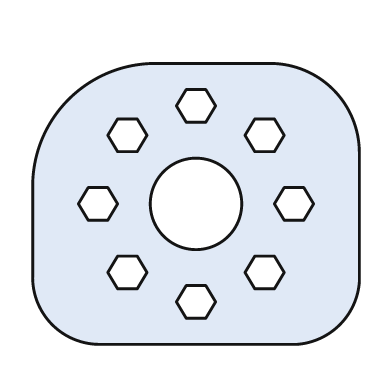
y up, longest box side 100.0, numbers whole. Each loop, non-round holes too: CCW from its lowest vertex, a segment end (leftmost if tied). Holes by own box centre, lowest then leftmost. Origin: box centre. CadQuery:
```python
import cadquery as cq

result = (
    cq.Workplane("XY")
    .moveTo(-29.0, -43.0)
    .lineTo(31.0, -43.0)
    .threePointArc((44.0, -37.0), (50.0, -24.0))
    .lineTo(50.0, 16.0)
    .threePointArc((42.0, 35.0), (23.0, 43.0))
    .lineTo(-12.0, 43.0)
    .threePointArc((-39.0, 32.0), (-50.0, 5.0))
    .lineTo(-50.0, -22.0)
    .threePointArc((-44.0, -37.0), (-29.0, -43.0))
    .close()
    .moveTo(-3.0, -35.0)
    .lineTo(3.0, -35.0)
    .lineTo(6.0, -30.0)
    .lineTo(3.0, -25.0)
    .lineTo(-3.0, -25.0)
    .lineTo(-6.0, -30.0)
    .close()
    .moveTo(-24.0, -26.0)
    .lineTo(-18.0, -26.0)
    .lineTo(-15.0, -21.0)
    .lineTo(-18.0, -16.0)
    .lineTo(-24.0, -16.0)
    .lineTo(-27.0, -21.0)
    .close()
    .moveTo(18.0, -26.0)
    .lineTo(24.0, -26.0)
    .lineTo(27.0, -21.0)
    .lineTo(24.0, -16.0)
    .lineTo(18.0, -16.0)
    .lineTo(15.0, -21.0)
    .close()
    .moveTo(-33.0, -5.0)
    .lineTo(-27.0, -5.0)
    .lineTo(-24.0, 0.0)
    .lineTo(-27.0, 5.0)
    .lineTo(-33.0, 5.0)
    .lineTo(-36.0, 0.0)
    .close()
    .moveTo(0.0, 0.0)
    .circle(14.0)
    .moveTo(27.0, -5.0)
    .lineTo(33.0, -5.0)
    .lineTo(36.0, 0.0)
    .lineTo(33.0, 5.0)
    .lineTo(27.0, 5.0)
    .lineTo(24.0, 0.0)
    .close()
    .moveTo(-24.0, 16.0)
    .lineTo(-18.0, 16.0)
    .lineTo(-15.0, 21.0)
    .lineTo(-18.0, 26.0)
    .lineTo(-24.0, 26.0)
    .lineTo(-27.0, 21.0)
    .close()
    .moveTo(18.0, 16.0)
    .lineTo(24.0, 16.0)
    .lineTo(27.0, 21.0)
    .lineTo(24.0, 26.0)
    .lineTo(18.0, 26.0)
    .lineTo(15.0, 21.0)
    .close()
    .moveTo(-3.0, 25.0)
    .lineTo(3.0, 25.0)
    .lineTo(6.0, 30.0)
    .lineTo(3.0, 35.0)
    .lineTo(-3.0, 35.0)
    .lineTo(-6.0, 30.0)
    .close()
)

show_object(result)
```